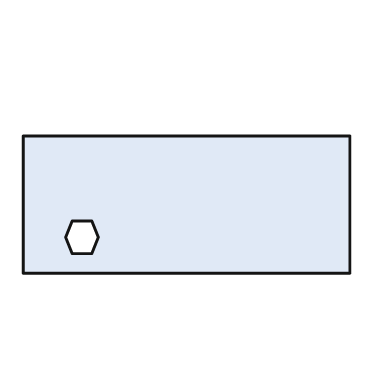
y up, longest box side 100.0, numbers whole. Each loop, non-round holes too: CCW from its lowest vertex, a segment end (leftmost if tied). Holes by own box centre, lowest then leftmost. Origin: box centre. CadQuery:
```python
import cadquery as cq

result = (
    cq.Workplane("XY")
    .moveTo(-50.0, -21.0)
    .lineTo(50.0, -21.0)
    .lineTo(50.0, 21.0)
    .lineTo(-50.0, 21.0)
    .close()
    .moveTo(-35.0, -15.0)
    .lineTo(-29.0, -15.0)
    .lineTo(-27.0, -10.0)
    .lineTo(-29.0, -5.0)
    .lineTo(-35.0, -5.0)
    .lineTo(-37.0, -10.0)
    .close()
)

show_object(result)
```